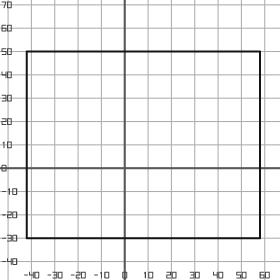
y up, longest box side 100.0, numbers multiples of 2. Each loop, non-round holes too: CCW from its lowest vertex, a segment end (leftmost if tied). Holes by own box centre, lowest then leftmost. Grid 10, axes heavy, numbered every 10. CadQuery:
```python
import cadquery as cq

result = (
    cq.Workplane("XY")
    .moveTo(-42.0, -30.0)
    .lineTo(58.0, -30.0)
    .lineTo(58.0, 50.0)
    .lineTo(-42.0, 50.0)
    .close()
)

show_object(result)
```